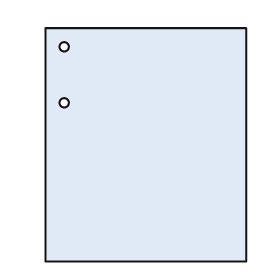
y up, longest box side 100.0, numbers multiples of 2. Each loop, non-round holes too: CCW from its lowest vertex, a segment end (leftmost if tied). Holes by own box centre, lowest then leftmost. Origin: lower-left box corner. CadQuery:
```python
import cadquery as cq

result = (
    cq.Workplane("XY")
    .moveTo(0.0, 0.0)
    .lineTo(86.0, 0.0)
    .lineTo(86.0, 100.0)
    .lineTo(0.0, 100.0)
    .close()
    .moveTo(8.0, 68.0)
    .circle(2.0)
    .moveTo(8.0, 92.0)
    .circle(2.0)
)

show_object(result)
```